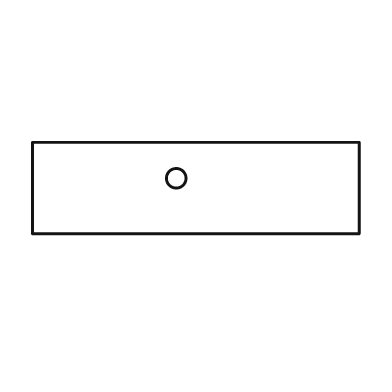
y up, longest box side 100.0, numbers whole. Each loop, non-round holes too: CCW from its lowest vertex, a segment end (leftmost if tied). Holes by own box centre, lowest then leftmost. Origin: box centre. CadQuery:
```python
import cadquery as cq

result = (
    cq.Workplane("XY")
    .moveTo(-50.0, -14.0)
    .lineTo(50.0, -14.0)
    .lineTo(50.0, 14.0)
    .lineTo(-50.0, 14.0)
    .close()
    .moveTo(-6.0, 3.0)
    .circle(3.0)
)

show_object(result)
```